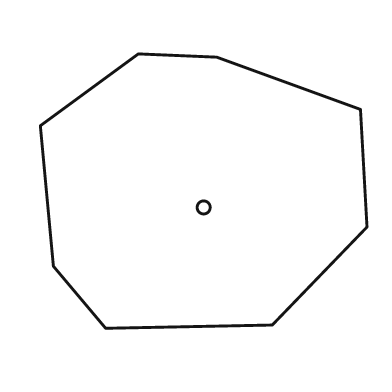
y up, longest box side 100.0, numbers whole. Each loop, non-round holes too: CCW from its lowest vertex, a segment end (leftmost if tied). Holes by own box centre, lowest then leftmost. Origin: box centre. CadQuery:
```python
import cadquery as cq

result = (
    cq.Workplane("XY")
    .moveTo(-30.0, -42.0)
    .lineTo(21.0, -41.0)
    .lineTo(50.0, -11.0)
    .lineTo(48.0, 25.0)
    .lineTo(4.0, 41.0)
    .lineTo(-20.0, 42.0)
    .lineTo(-50.0, 20.0)
    .lineTo(-46.0, -23.0)
    .close()
    .moveTo(0.0, -5.0)
    .circle(2.0)
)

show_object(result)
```